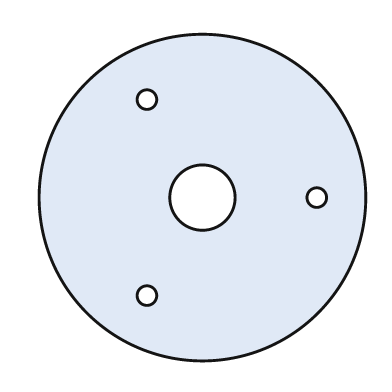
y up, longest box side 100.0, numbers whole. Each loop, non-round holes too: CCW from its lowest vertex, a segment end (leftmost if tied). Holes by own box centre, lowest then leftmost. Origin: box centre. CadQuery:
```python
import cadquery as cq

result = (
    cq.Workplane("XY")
    .moveTo(0.0, 0.0)
    .circle(50.0)
    .moveTo(-17.0, -30.0)
    .circle(3.0)
    .moveTo(0.0, 0.0)
    .circle(10.0)
    .moveTo(35.0, 0.0)
    .circle(3.0)
    .moveTo(-17.0, 30.0)
    .circle(3.0)
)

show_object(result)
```